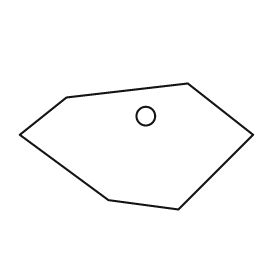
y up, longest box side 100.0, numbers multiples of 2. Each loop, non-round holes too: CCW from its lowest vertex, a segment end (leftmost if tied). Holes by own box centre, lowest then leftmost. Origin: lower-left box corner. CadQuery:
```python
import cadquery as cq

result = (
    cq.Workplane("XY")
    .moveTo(68.0, 0.0)
    .lineTo(100.0, 32.0)
    .lineTo(72.0, 54.0)
    .lineTo(20.0, 48.0)
    .lineTo(0.0, 32.0)
    .lineTo(38.0, 4.0)
    .close()
    .moveTo(54.0, 40.0)
    .circle(4.0)
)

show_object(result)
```